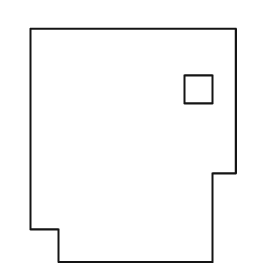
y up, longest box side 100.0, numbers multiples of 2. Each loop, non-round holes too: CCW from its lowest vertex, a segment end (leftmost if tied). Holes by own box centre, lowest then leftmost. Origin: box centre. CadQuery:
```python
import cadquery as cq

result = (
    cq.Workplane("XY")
    .moveTo(-32.0, -50.0)
    .lineTo(34.0, -50.0)
    .lineTo(34.0, -12.0)
    .lineTo(44.0, -12.0)
    .lineTo(44.0, 50.0)
    .lineTo(-44.0, 50.0)
    .lineTo(-44.0, -36.0)
    .lineTo(-32.0, -36.0)
    .close()
    .moveTo(22.0, 18.0)
    .lineTo(34.0, 18.0)
    .lineTo(34.0, 30.0)
    .lineTo(22.0, 30.0)
    .close()
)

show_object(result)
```